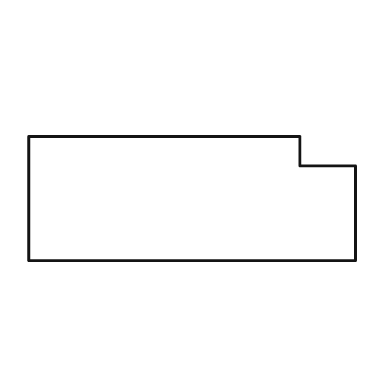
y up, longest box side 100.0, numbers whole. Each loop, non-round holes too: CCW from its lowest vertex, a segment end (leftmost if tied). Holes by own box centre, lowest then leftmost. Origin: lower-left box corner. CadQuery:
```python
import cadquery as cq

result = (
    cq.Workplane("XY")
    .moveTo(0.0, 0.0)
    .lineTo(100.0, 0.0)
    .lineTo(100.0, 29.0)
    .lineTo(83.0, 29.0)
    .lineTo(83.0, 38.0)
    .lineTo(0.0, 38.0)
    .close()
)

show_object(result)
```